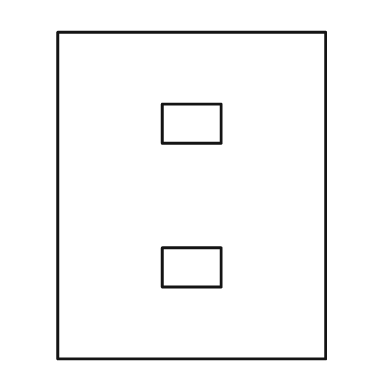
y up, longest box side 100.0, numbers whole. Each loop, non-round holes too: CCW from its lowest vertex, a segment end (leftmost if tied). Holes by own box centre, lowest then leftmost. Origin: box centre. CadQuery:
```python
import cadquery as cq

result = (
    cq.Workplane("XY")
    .moveTo(-41.0, -50.0)
    .lineTo(41.0, -50.0)
    .lineTo(41.0, 50.0)
    .lineTo(-41.0, 50.0)
    .close()
    .moveTo(-9.0, -28.0)
    .lineTo(9.0, -28.0)
    .lineTo(9.0, -16.0)
    .lineTo(-9.0, -16.0)
    .close()
    .moveTo(-9.0, 16.0)
    .lineTo(9.0, 16.0)
    .lineTo(9.0, 28.0)
    .lineTo(-9.0, 28.0)
    .close()
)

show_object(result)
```